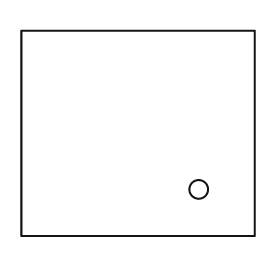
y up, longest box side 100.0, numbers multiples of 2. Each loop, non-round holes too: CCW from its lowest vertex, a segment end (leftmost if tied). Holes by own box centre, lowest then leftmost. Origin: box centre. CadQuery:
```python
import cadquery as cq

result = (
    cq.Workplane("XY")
    .moveTo(-50.0, -44.0)
    .lineTo(50.0, -44.0)
    .lineTo(50.0, 44.0)
    .lineTo(-50.0, 44.0)
    .close()
    .moveTo(26.0, -24.0)
    .circle(4.0)
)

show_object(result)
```